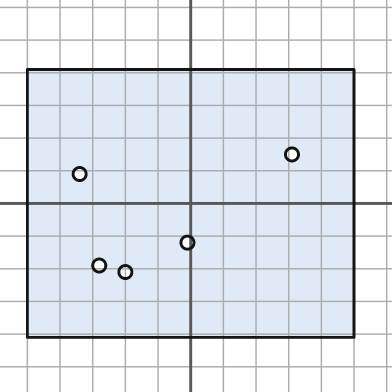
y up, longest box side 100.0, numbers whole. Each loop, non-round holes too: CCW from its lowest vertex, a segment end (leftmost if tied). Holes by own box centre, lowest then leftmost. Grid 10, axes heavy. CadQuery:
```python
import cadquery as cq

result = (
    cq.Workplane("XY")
    .moveTo(-50.0, -41.0)
    .lineTo(50.0, -41.0)
    .lineTo(50.0, 41.0)
    .lineTo(-50.0, 41.0)
    .close()
    .moveTo(-20.0, -21.0)
    .circle(2.0)
    .moveTo(-28.0, -19.0)
    .circle(2.0)
    .moveTo(-1.0, -12.0)
    .circle(2.0)
    .moveTo(-34.0, 9.0)
    .circle(2.0)
    .moveTo(31.0, 15.0)
    .circle(2.0)
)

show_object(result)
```